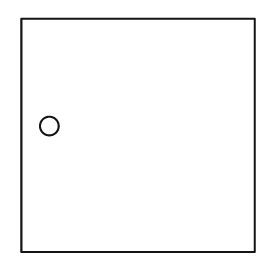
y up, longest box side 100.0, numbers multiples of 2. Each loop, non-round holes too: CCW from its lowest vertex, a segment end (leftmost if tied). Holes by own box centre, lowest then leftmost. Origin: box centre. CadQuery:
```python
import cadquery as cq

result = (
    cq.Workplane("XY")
    .moveTo(-50.0, -50.0)
    .lineTo(50.0, -50.0)
    .lineTo(50.0, 50.0)
    .lineTo(-50.0, 50.0)
    .close()
    .moveTo(-38.0, 4.0)
    .circle(4.0)
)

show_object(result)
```